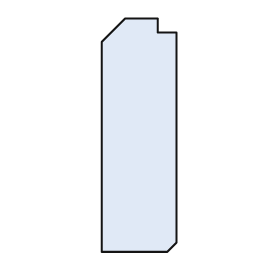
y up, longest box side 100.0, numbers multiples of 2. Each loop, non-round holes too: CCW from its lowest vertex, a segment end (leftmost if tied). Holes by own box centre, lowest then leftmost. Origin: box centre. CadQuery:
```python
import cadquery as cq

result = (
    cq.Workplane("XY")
    .moveTo(-16.0, -50.0)
    .lineTo(12.0, -50.0)
    .lineTo(16.0, -46.0)
    .lineTo(16.0, 44.0)
    .lineTo(8.0, 44.0)
    .lineTo(8.0, 50.0)
    .lineTo(-6.0, 50.0)
    .lineTo(-16.0, 40.0)
    .close()
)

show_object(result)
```